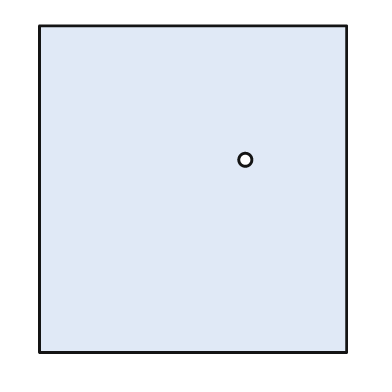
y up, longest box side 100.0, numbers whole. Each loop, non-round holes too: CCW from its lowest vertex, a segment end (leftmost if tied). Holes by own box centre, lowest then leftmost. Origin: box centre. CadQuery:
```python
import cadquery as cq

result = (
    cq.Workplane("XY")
    .moveTo(-47.0, -50.0)
    .lineTo(47.0, -50.0)
    .lineTo(47.0, 50.0)
    .lineTo(-47.0, 50.0)
    .close()
    .moveTo(16.0, 9.0)
    .circle(2.0)
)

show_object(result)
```